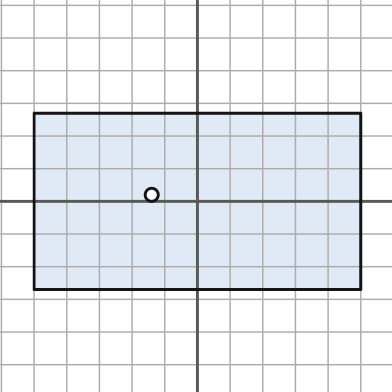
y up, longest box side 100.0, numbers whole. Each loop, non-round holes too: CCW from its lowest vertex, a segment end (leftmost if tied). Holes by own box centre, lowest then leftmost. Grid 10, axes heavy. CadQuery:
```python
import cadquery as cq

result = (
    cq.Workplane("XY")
    .moveTo(-50.0, -27.0)
    .lineTo(50.0, -27.0)
    .lineTo(50.0, 27.0)
    .lineTo(-50.0, 27.0)
    .close()
    .moveTo(-14.0, 2.0)
    .circle(2.0)
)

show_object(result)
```